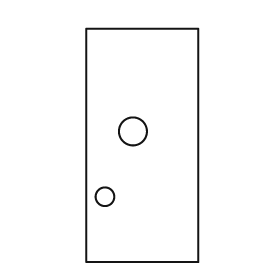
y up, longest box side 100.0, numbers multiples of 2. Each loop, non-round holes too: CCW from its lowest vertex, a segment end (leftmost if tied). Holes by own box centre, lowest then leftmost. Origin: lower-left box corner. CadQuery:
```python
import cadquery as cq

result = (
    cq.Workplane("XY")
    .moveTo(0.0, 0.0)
    .lineTo(48.0, 0.0)
    .lineTo(48.0, 100.0)
    .lineTo(0.0, 100.0)
    .close()
    .moveTo(8.0, 28.0)
    .circle(4.0)
    .moveTo(20.0, 56.0)
    .circle(6.0)
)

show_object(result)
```